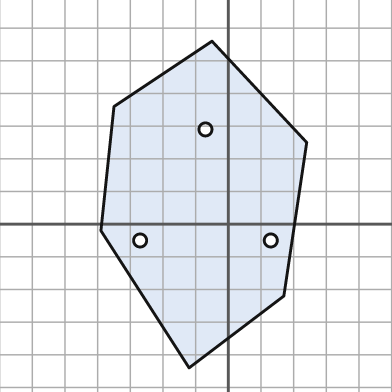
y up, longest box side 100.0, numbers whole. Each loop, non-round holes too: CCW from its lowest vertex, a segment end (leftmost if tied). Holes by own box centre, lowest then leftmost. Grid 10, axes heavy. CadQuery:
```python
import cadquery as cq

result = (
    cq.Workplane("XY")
    .moveTo(-12.0, -44.0)
    .lineTo(17.0, -22.0)
    .lineTo(24.0, 25.0)
    .lineTo(-5.0, 56.0)
    .lineTo(-35.0, 36.0)
    .lineTo(-39.0, -2.0)
    .close()
    .moveTo(-27.0, -5.0)
    .circle(2.0)
    .moveTo(13.0, -5.0)
    .circle(2.0)
    .moveTo(-7.0, 29.0)
    .circle(2.0)
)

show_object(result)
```